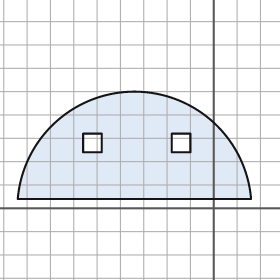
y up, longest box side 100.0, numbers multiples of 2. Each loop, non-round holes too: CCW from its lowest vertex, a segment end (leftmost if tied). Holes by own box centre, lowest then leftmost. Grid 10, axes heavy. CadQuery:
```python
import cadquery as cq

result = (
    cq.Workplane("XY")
    .moveTo(-84.0, 4.0)
    .lineTo(16.0, 4.0)
    .threePointArc((-34.0, 50.0), (-84.0, 4.0))
    .close()
    .moveTo(-56.0, 24.0)
    .lineTo(-48.0, 24.0)
    .lineTo(-48.0, 32.0)
    .lineTo(-56.0, 32.0)
    .close()
    .moveTo(-18.0, 24.0)
    .lineTo(-10.0, 24.0)
    .lineTo(-10.0, 32.0)
    .lineTo(-18.0, 32.0)
    .close()
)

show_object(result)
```